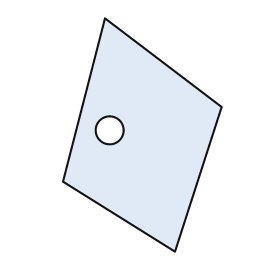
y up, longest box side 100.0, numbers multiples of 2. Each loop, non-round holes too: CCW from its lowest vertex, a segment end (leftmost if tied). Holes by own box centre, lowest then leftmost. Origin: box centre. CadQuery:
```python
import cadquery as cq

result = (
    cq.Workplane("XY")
    .moveTo(14.0, -50.0)
    .lineTo(34.0, 12.0)
    .lineTo(-16.0, 50.0)
    .lineTo(-34.0, -20.0)
    .close()
    .moveTo(-14.0, 2.0)
    .circle(6.0)
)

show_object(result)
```